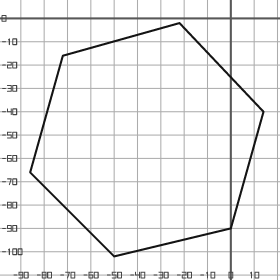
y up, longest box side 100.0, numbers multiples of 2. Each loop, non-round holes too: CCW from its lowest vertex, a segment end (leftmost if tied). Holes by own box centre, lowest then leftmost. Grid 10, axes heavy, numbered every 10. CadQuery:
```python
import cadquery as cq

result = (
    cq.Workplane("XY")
    .moveTo(-50.0, -102.0)
    .lineTo(0.0, -90.0)
    .lineTo(14.0, -40.0)
    .lineTo(-22.0, -2.0)
    .lineTo(-72.0, -16.0)
    .lineTo(-86.0, -66.0)
    .close()
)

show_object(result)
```